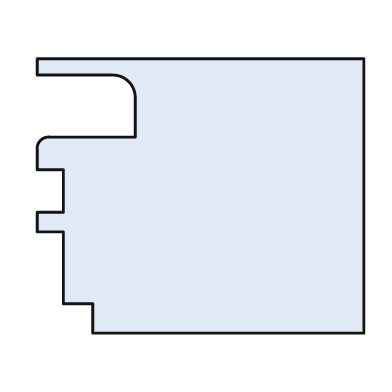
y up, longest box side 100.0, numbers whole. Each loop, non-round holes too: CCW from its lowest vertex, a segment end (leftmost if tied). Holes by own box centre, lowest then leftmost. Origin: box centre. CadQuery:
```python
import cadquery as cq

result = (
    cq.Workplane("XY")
    .moveTo(-33.0, -42.0)
    .lineTo(50.0, -42.0)
    .lineTo(50.0, 42.0)
    .lineTo(-50.0, 42.0)
    .lineTo(-50.0, 37.0)
    .lineTo(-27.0, 37.0)
    .threePointArc((-22.0, 35.0), (-20.0, 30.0))
    .lineTo(-20.0, 18.0)
    .lineTo(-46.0, 18.0)
    .threePointArc((-49.0, 17.0), (-50.0, 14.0))
    .lineTo(-50.0, 8.0)
    .lineTo(-42.0, 8.0)
    .lineTo(-42.0, -5.0)
    .lineTo(-50.0, -5.0)
    .lineTo(-50.0, -11.0)
    .lineTo(-42.0, -11.0)
    .lineTo(-42.0, -33.0)
    .lineTo(-33.0, -33.0)
    .close()
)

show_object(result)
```